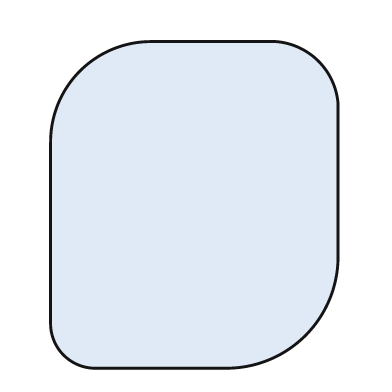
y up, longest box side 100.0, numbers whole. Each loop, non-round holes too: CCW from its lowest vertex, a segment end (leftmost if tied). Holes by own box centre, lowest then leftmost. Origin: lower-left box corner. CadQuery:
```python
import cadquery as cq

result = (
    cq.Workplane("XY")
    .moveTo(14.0, 0.0)
    .lineTo(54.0, 0.0)
    .threePointArc((78.0, 10.0), (88.0, 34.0))
    .lineTo(88.0, 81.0)
    .threePointArc((82.0, 94.0), (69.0, 100.0))
    .lineTo(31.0, 100.0)
    .threePointArc((9.0, 91.0), (0.0, 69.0))
    .lineTo(0.0, 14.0)
    .threePointArc((4.0, 4.0), (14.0, 0.0))
    .close()
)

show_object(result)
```